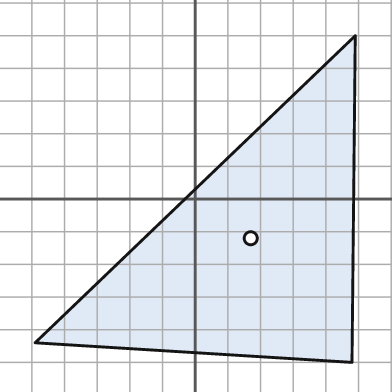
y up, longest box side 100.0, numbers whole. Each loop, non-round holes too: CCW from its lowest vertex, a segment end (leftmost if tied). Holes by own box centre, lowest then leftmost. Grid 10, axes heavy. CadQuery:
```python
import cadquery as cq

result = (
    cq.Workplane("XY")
    .moveTo(48.0, -50.0)
    .lineTo(49.0, 50.0)
    .lineTo(-49.0, -44.0)
    .close()
    .moveTo(17.0, -12.0)
    .circle(2.0)
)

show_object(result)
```